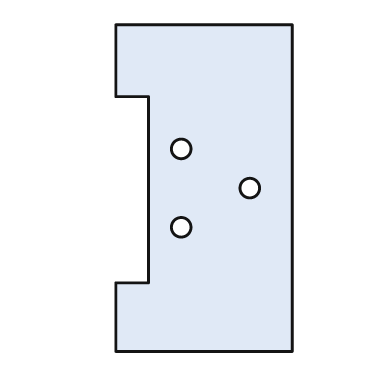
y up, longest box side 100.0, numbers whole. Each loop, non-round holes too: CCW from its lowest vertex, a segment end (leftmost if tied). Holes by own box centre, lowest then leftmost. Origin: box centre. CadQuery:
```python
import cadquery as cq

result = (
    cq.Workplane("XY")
    .moveTo(-27.0, -50.0)
    .lineTo(27.0, -50.0)
    .lineTo(27.0, 50.0)
    .lineTo(-27.0, 50.0)
    .lineTo(-27.0, 28.0)
    .lineTo(-17.0, 28.0)
    .lineTo(-17.0, -29.0)
    .lineTo(-27.0, -29.0)
    .close()
    .moveTo(-7.0, -12.0)
    .circle(3.0)
    .moveTo(14.0, 0.0)
    .circle(3.0)
    .moveTo(-7.0, 12.0)
    .circle(3.0)
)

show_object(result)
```